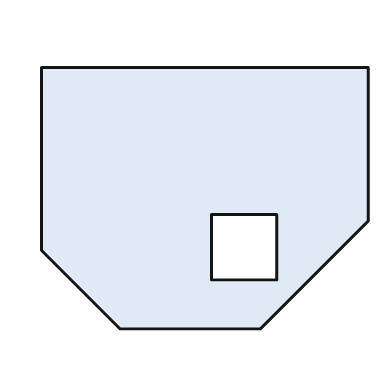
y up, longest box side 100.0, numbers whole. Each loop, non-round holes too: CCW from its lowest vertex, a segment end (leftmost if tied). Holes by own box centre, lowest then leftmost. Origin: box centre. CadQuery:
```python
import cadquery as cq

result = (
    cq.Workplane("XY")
    .moveTo(-26.0, -40.0)
    .lineTo(17.0, -40.0)
    .lineTo(50.0, -7.0)
    .lineTo(50.0, 40.0)
    .lineTo(-50.0, 40.0)
    .lineTo(-50.0, -16.0)
    .close()
    .moveTo(2.0, -25.0)
    .lineTo(22.0, -25.0)
    .lineTo(22.0, -5.0)
    .lineTo(2.0, -5.0)
    .close()
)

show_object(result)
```